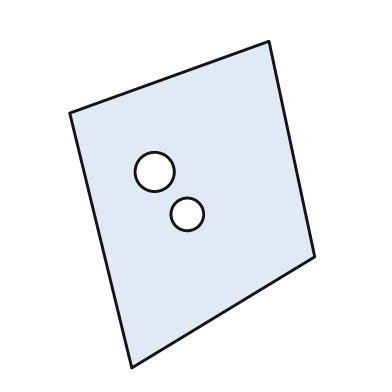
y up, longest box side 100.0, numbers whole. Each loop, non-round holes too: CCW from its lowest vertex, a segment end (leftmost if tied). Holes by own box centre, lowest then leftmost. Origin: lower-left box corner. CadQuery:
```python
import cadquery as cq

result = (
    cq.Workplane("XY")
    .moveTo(19.0, 0.0)
    .lineTo(75.0, 34.0)
    .lineTo(61.0, 100.0)
    .lineTo(0.0, 78.0)
    .close()
    .moveTo(36.0, 47.0)
    .circle(5.0)
    .moveTo(26.0, 60.0)
    .circle(6.0)
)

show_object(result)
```